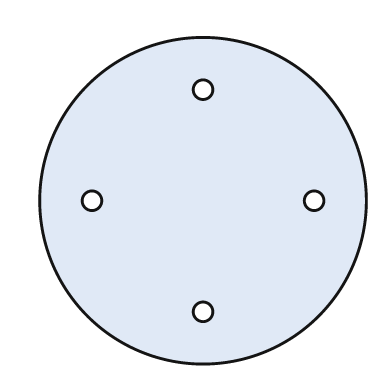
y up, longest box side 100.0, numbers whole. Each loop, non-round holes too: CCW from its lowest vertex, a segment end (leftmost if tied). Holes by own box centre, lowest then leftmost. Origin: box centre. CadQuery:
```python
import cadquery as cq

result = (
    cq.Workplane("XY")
    .moveTo(0.0, 0.0)
    .circle(50.0)
    .moveTo(0.0, -34.0)
    .circle(3.0)
    .moveTo(-34.0, 0.0)
    .circle(3.0)
    .moveTo(34.0, 0.0)
    .circle(3.0)
    .moveTo(0.0, 34.0)
    .circle(3.0)
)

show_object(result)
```